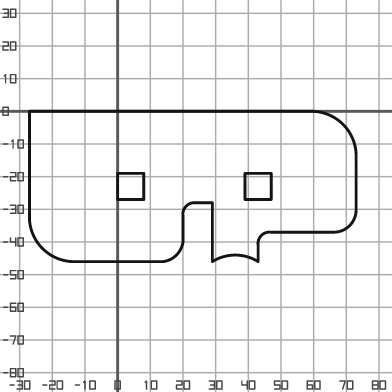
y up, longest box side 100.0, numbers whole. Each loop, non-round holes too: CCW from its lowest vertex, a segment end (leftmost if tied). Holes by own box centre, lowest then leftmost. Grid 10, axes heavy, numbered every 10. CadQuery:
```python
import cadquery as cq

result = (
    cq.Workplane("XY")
    .moveTo(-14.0, -46.0)
    .lineTo(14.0, -46.0)
    .threePointArc((18.0, -44.0), (20.0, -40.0))
    .lineTo(20.0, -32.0)
    .threePointArc((21.0, -29.0), (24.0, -28.0))
    .lineTo(29.0, -28.0)
    .lineTo(29.0, -46.0)
    .threePointArc((36.0, -44.0), (43.0, -46.0))
    .lineTo(43.0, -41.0)
    .threePointArc((44.0, -38.0), (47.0, -37.0))
    .lineTo(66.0, -37.0)
    .threePointArc((71.0, -35.0), (73.0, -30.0))
    .lineTo(73.0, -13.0)
    .threePointArc((69.0, -4.0), (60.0, 0.0))
    .lineTo(-27.0, 0.0)
    .lineTo(-27.0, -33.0)
    .threePointArc((-23.0, -42.0), (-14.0, -46.0))
    .close()
    .moveTo(0.0, -27.0)
    .lineTo(8.0, -27.0)
    .lineTo(8.0, -19.0)
    .lineTo(0.0, -19.0)
    .close()
    .moveTo(39.0, -27.0)
    .lineTo(47.0, -27.0)
    .lineTo(47.0, -19.0)
    .lineTo(39.0, -19.0)
    .close()
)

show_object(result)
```